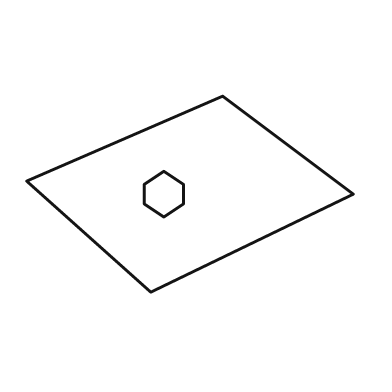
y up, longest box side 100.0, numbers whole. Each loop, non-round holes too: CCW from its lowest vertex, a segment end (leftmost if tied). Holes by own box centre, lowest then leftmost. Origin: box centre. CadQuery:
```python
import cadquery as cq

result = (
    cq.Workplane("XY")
    .moveTo(-12.0, -30.0)
    .lineTo(50.0, 0.0)
    .lineTo(10.0, 30.0)
    .lineTo(-50.0, 4.0)
    .close()
    .moveTo(-8.0, -7.0)
    .lineTo(-2.0, -3.0)
    .lineTo(-2.0, 3.0)
    .lineTo(-8.0, 7.0)
    .lineTo(-14.0, 3.0)
    .lineTo(-14.0, -3.0)
    .close()
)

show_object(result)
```